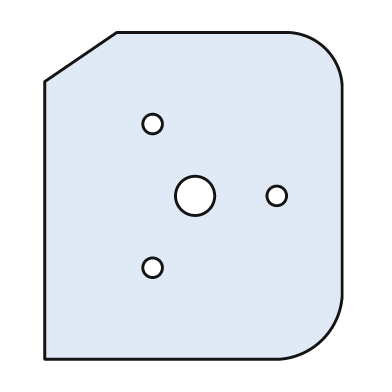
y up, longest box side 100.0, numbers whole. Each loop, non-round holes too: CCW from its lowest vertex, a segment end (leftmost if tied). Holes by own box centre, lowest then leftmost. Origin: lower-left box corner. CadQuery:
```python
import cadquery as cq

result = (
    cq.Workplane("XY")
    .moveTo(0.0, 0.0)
    .lineTo(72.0, 0.0)
    .threePointArc((85.0, 6.0), (91.0, 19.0))
    .lineTo(91.0, 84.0)
    .threePointArc((86.0, 95.0), (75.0, 100.0))
    .lineTo(22.0, 100.0)
    .lineTo(0.0, 85.0)
    .close()
    .moveTo(33.0, 28.0)
    .circle(3.0)
    .moveTo(46.0, 50.0)
    .circle(6.0)
    .moveTo(71.0, 50.0)
    .circle(3.0)
    .moveTo(33.0, 72.0)
    .circle(3.0)
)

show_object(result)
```